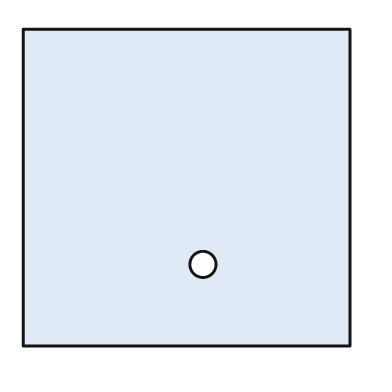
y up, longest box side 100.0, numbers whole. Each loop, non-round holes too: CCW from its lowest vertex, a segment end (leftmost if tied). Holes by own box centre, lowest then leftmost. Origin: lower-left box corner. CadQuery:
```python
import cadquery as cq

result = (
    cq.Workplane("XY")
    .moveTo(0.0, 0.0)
    .lineTo(100.0, 0.0)
    .lineTo(100.0, 97.0)
    .lineTo(0.0, 97.0)
    .close()
    .moveTo(55.0, 25.0)
    .circle(4.0)
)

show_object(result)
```